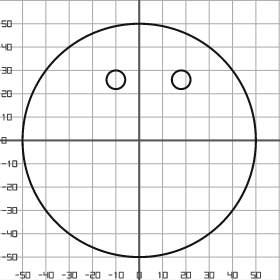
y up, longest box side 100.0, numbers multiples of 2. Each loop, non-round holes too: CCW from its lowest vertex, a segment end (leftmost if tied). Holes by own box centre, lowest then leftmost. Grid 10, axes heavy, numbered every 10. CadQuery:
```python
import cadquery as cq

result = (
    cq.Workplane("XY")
    .moveTo(0.0, 0.0)
    .circle(50.0)
    .moveTo(-10.0, 26.0)
    .circle(4.0)
    .moveTo(18.0, 26.0)
    .circle(4.0)
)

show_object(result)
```